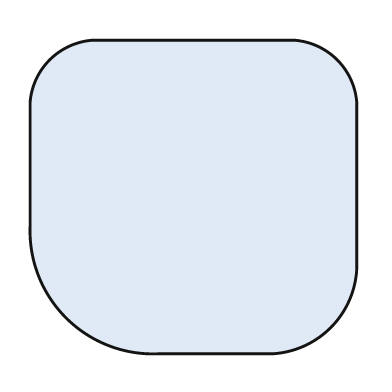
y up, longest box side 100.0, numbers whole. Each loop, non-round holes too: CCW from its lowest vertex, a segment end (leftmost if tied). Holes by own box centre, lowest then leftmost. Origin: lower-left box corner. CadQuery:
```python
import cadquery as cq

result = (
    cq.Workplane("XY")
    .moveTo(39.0, 0.0)
    .lineTo(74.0, 0.0)
    .threePointArc((92.0, 8.0), (100.0, 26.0))
    .lineTo(100.0, 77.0)
    .threePointArc((94.0, 90.0), (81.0, 96.0))
    .lineTo(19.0, 96.0)
    .threePointArc((6.0, 90.0), (0.0, 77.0))
    .lineTo(0.0, 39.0)
    .threePointArc((11.0, 11.0), (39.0, 0.0))
    .close()
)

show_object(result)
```